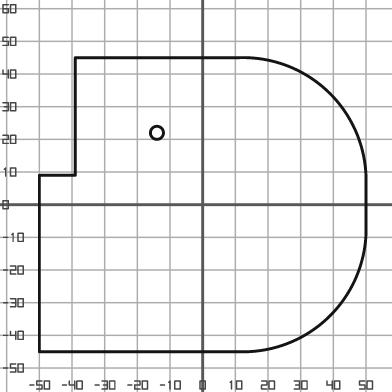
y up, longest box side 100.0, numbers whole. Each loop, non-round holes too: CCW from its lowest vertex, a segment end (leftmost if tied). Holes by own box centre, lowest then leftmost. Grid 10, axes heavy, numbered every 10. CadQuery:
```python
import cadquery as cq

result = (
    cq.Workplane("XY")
    .moveTo(-50.0, -45.0)
    .lineTo(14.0, -45.0)
    .threePointArc((39.0, -34.0), (50.0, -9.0))
    .lineTo(50.0, 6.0)
    .threePointArc((39.0, 34.0), (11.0, 45.0))
    .lineTo(-39.0, 45.0)
    .lineTo(-39.0, 9.0)
    .lineTo(-50.0, 9.0)
    .close()
    .moveTo(-14.0, 22.0)
    .circle(2.0)
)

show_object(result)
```